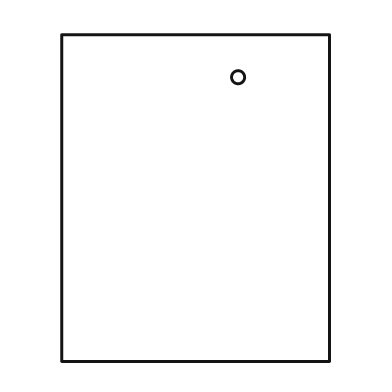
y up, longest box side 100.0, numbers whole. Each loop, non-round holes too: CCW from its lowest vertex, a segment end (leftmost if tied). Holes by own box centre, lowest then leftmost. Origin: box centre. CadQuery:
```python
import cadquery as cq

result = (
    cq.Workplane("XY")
    .moveTo(-41.0, -50.0)
    .lineTo(41.0, -50.0)
    .lineTo(41.0, 50.0)
    .lineTo(-41.0, 50.0)
    .close()
    .moveTo(13.0, 37.0)
    .circle(2.0)
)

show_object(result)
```